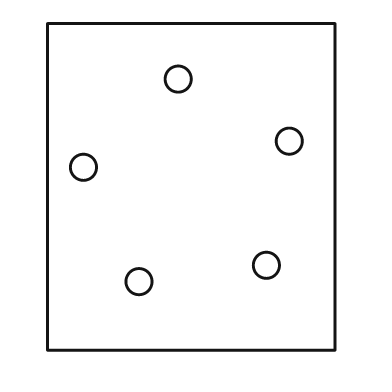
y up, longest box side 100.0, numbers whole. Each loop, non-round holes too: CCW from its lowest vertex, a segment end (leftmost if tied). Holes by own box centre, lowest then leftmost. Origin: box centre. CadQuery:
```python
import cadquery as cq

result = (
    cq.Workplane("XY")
    .moveTo(-44.0, -50.0)
    .lineTo(44.0, -50.0)
    .lineTo(44.0, 50.0)
    .lineTo(-44.0, 50.0)
    .close()
    .moveTo(-16.0, -29.0)
    .circle(4.0)
    .moveTo(23.0, -24.0)
    .circle(4.0)
    .moveTo(-33.0, 6.0)
    .circle(4.0)
    .moveTo(30.0, 14.0)
    .circle(4.0)
    .moveTo(-4.0, 33.0)
    .circle(4.0)
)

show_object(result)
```